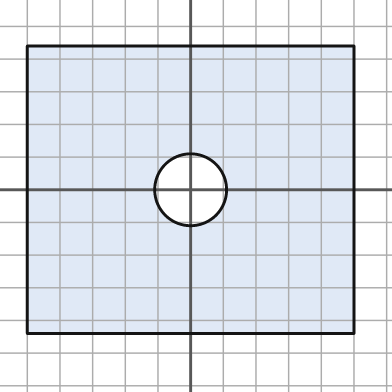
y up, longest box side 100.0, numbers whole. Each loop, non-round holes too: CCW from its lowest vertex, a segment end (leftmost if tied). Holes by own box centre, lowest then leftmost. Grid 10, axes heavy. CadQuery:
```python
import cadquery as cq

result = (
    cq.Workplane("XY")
    .moveTo(-50.0, -44.0)
    .lineTo(50.0, -44.0)
    .lineTo(50.0, 44.0)
    .lineTo(-50.0, 44.0)
    .close()
    .moveTo(0.0, 0.0)
    .circle(11.0)
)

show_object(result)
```